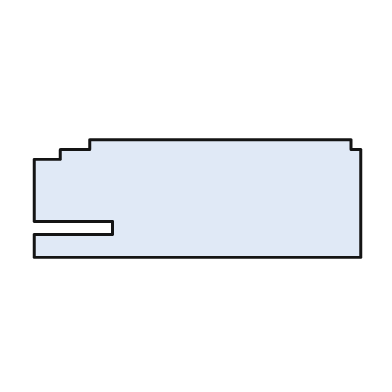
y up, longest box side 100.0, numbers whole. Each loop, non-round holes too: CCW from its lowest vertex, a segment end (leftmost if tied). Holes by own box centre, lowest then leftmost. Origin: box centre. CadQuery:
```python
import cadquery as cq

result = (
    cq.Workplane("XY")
    .moveTo(-50.0, -18.0)
    .lineTo(50.0, -18.0)
    .lineTo(50.0, 15.0)
    .lineTo(47.0, 15.0)
    .lineTo(47.0, 18.0)
    .lineTo(-33.0, 18.0)
    .lineTo(-33.0, 15.0)
    .lineTo(-42.0, 15.0)
    .lineTo(-42.0, 12.0)
    .lineTo(-50.0, 12.0)
    .lineTo(-50.0, -7.0)
    .lineTo(-26.0, -7.0)
    .lineTo(-26.0, -11.0)
    .lineTo(-50.0, -11.0)
    .close()
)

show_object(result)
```